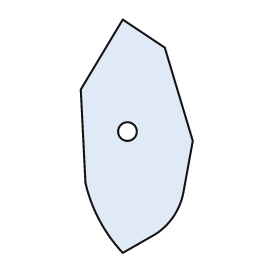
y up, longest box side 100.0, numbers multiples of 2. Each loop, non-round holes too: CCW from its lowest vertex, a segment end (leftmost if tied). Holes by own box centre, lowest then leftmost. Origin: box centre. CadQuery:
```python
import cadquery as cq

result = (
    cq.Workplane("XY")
    .moveTo(-6.0, -50.0)
    .lineTo(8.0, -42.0)
    .threePointArc((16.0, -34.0), (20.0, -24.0))
    .lineTo(24.0, -2.0)
    .lineTo(12.0, 38.0)
    .lineTo(-6.0, 50.0)
    .lineTo(-24.0, 20.0)
    .lineTo(-22.0, -20.0)
    .threePointArc((-16.0, -36.0), (-6.0, -50.0))
    .close()
    .moveTo(-4.0, 2.0)
    .circle(4.0)
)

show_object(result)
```